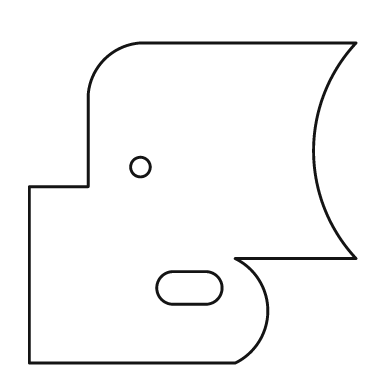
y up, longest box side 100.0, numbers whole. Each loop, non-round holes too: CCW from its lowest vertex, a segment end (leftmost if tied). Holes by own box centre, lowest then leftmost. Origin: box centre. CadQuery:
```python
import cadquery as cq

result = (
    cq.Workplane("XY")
    .moveTo(-50.0, -49.0)
    .lineTo(13.0, -49.0)
    .threePointArc((23.0, -33.0), (13.0, -17.0))
    .lineTo(50.0, -17.0)
    .threePointArc((37.0, 16.0), (50.0, 49.0))
    .lineTo(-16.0, 49.0)
    .threePointArc((-27.0, 44.0), (-32.0, 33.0))
    .lineTo(-32.0, 5.0)
    .lineTo(-50.0, 5.0)
    .close()
    .moveTo(-6.0, -31.0)
    .lineTo(4.0, -31.0)
    .threePointArc((9.0, -26.0), (4.0, -21.0))
    .lineTo(-6.0, -21.0)
    .threePointArc((-11.0, -26.0), (-6.0, -31.0))
    .close()
    .moveTo(-16.0, 11.0)
    .circle(3.0)
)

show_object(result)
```